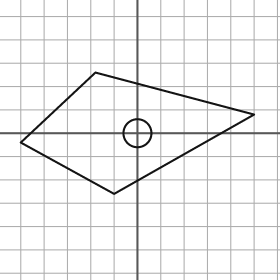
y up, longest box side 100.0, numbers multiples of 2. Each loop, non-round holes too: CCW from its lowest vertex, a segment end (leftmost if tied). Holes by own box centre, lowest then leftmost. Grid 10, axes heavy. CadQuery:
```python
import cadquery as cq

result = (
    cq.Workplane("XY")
    .moveTo(-10.0, -26.0)
    .lineTo(50.0, 8.0)
    .lineTo(-18.0, 26.0)
    .lineTo(-50.0, -4.0)
    .close()
    .moveTo(0.0, 0.0)
    .circle(6.0)
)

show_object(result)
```